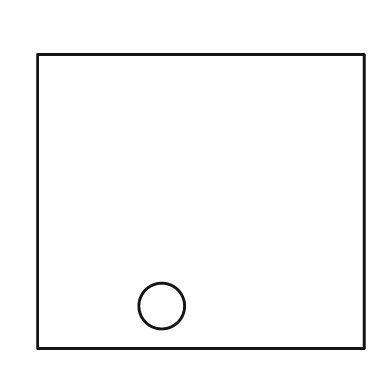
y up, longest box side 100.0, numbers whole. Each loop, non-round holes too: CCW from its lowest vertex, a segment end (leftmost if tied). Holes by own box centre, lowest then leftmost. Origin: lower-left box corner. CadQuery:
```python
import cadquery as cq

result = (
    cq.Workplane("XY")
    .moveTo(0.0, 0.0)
    .lineTo(100.0, 0.0)
    .lineTo(100.0, 90.0)
    .lineTo(0.0, 90.0)
    .close()
    .moveTo(38.0, 13.0)
    .circle(7.0)
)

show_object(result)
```